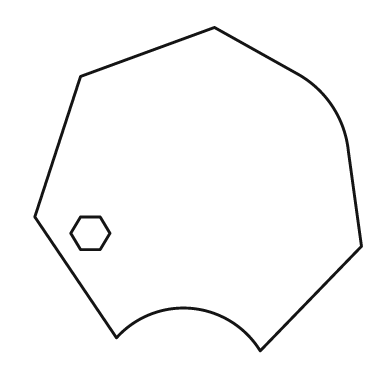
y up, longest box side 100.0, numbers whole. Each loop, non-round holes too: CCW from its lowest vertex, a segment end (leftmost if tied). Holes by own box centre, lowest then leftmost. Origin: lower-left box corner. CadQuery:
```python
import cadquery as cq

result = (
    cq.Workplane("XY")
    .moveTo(69.0, 0.0)
    .lineTo(100.0, 32.0)
    .lineTo(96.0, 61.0)
    .threePointArc((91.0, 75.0), (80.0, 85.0))
    .lineTo(55.0, 99.0)
    .lineTo(14.0, 84.0)
    .lineTo(0.0, 41.0)
    .lineTo(25.0, 4.0)
    .threePointArc((48.0, 13.0), (69.0, 0.0))
    .close()
    .moveTo(14.0, 31.0)
    .lineTo(20.0, 31.0)
    .lineTo(23.0, 36.0)
    .lineTo(20.0, 41.0)
    .lineTo(14.0, 41.0)
    .lineTo(11.0, 36.0)
    .close()
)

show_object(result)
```